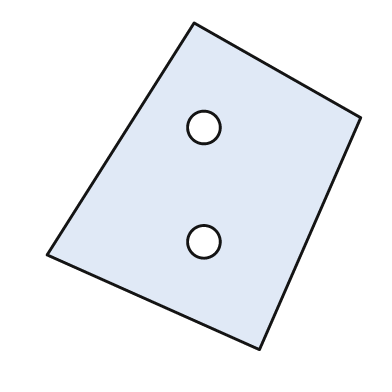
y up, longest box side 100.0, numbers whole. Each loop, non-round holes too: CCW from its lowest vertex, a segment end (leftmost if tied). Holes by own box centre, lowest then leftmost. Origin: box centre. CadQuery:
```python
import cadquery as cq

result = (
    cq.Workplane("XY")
    .moveTo(17.0, -50.0)
    .lineTo(48.0, 21.0)
    .lineTo(-3.0, 50.0)
    .lineTo(-48.0, -21.0)
    .close()
    .moveTo(0.0, -17.0)
    .circle(5.0)
    .moveTo(0.0, 18.0)
    .circle(5.0)
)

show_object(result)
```